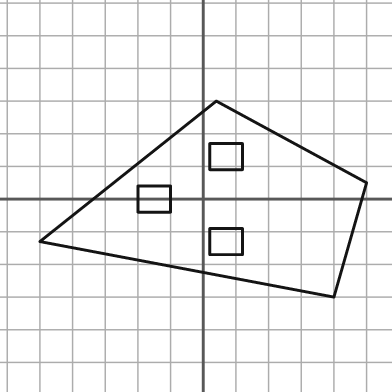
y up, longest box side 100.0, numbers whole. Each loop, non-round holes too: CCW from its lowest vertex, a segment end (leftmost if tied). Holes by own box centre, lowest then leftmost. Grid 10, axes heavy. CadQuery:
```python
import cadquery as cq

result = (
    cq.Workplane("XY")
    .moveTo(40.0, -30.0)
    .lineTo(50.0, 5.0)
    .lineTo(4.0, 30.0)
    .lineTo(-50.0, -13.0)
    .close()
    .moveTo(2.0, -17.0)
    .lineTo(12.0, -17.0)
    .lineTo(12.0, -9.0)
    .lineTo(2.0, -9.0)
    .close()
    .moveTo(-20.0, -4.0)
    .lineTo(-10.0, -4.0)
    .lineTo(-10.0, 4.0)
    .lineTo(-20.0, 4.0)
    .close()
    .moveTo(2.0, 9.0)
    .lineTo(12.0, 9.0)
    .lineTo(12.0, 17.0)
    .lineTo(2.0, 17.0)
    .close()
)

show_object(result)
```